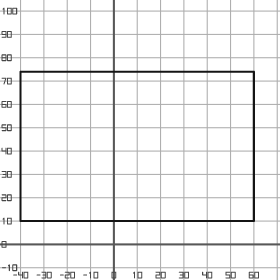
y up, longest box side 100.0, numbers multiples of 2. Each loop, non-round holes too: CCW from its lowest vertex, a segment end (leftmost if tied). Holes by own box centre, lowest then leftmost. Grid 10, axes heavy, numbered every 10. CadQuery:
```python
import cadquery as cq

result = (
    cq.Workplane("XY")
    .moveTo(-40.0, 10.0)
    .lineTo(60.0, 10.0)
    .lineTo(60.0, 74.0)
    .lineTo(-40.0, 74.0)
    .close()
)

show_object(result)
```